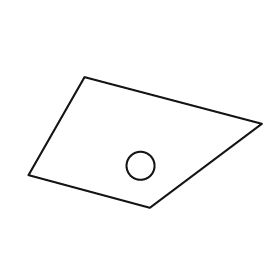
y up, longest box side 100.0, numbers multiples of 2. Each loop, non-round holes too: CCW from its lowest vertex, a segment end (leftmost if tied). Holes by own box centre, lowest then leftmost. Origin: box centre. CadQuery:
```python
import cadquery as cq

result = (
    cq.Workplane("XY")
    .moveTo(2.0, -28.0)
    .lineTo(50.0, 8.0)
    .lineTo(-26.0, 28.0)
    .lineTo(-50.0, -14.0)
    .close()
    .moveTo(-2.0, -10.0)
    .circle(6.0)
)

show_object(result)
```